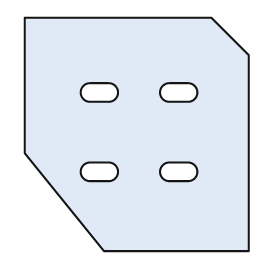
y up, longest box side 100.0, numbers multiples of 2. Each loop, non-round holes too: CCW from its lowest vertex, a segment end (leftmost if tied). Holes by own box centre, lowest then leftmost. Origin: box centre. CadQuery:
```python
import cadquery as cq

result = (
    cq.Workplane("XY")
    .moveTo(-14.0, -50.0)
    .lineTo(48.0, -50.0)
    .lineTo(48.0, 34.0)
    .lineTo(32.0, 50.0)
    .lineTo(-48.0, 50.0)
    .lineTo(-48.0, -8.0)
    .close()
    .moveTo(-20.0, -20.0)
    .lineTo(-12.0, -20.0)
    .threePointArc((-8.0, -16.0), (-12.0, -12.0))
    .lineTo(-20.0, -12.0)
    .threePointArc((-24.0, -16.0), (-20.0, -20.0))
    .close()
    .moveTo(14.0, -20.0)
    .lineTo(22.0, -20.0)
    .threePointArc((26.0, -16.0), (22.0, -12.0))
    .lineTo(14.0, -12.0)
    .threePointArc((10.0, -16.0), (14.0, -20.0))
    .close()
    .moveTo(-20.0, 14.0)
    .lineTo(-12.0, 14.0)
    .threePointArc((-8.0, 18.0), (-12.0, 22.0))
    .lineTo(-20.0, 22.0)
    .threePointArc((-24.0, 18.0), (-20.0, 14.0))
    .close()
    .moveTo(14.0, 14.0)
    .lineTo(22.0, 14.0)
    .threePointArc((26.0, 18.0), (22.0, 22.0))
    .lineTo(14.0, 22.0)
    .threePointArc((10.0, 18.0), (14.0, 14.0))
    .close()
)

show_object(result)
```